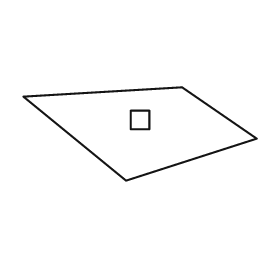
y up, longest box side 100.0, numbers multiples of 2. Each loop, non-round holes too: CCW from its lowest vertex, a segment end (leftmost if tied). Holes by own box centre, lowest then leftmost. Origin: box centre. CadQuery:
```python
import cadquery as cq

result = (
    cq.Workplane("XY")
    .moveTo(-6.0, -20.0)
    .lineTo(50.0, -2.0)
    .lineTo(18.0, 20.0)
    .lineTo(-50.0, 16.0)
    .close()
    .moveTo(-4.0, 2.0)
    .lineTo(4.0, 2.0)
    .lineTo(4.0, 10.0)
    .lineTo(-4.0, 10.0)
    .close()
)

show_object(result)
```